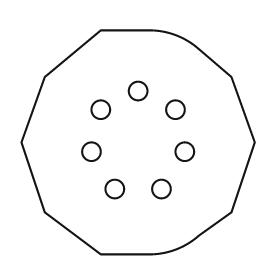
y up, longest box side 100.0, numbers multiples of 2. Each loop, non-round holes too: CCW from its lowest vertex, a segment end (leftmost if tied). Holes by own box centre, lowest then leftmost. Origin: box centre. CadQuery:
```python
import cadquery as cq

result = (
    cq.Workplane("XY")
    .moveTo(-16.0, -48.0)
    .lineTo(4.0, -48.0)
    .threePointArc((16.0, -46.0), (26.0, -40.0))
    .lineTo(40.0, -30.0)
    .lineTo(50.0, 0.0)
    .lineTo(40.0, 28.0)
    .lineTo(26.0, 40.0)
    .threePointArc((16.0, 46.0), (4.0, 48.0))
    .lineTo(-16.0, 48.0)
    .lineTo(-40.0, 28.0)
    .lineTo(-50.0, 0.0)
    .lineTo(-40.0, -30.0)
    .close()
    .moveTo(-10.0, -20.0)
    .circle(4.0)
    .moveTo(10.0, -20.0)
    .circle(4.0)
    .moveTo(-20.0, -4.0)
    .circle(4.0)
    .moveTo(20.0, -4.0)
    .circle(4.0)
    .moveTo(-16.0, 14.0)
    .circle(4.0)
    .moveTo(16.0, 14.0)
    .circle(4.0)
    .moveTo(0.0, 22.0)
    .circle(4.0)
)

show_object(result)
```